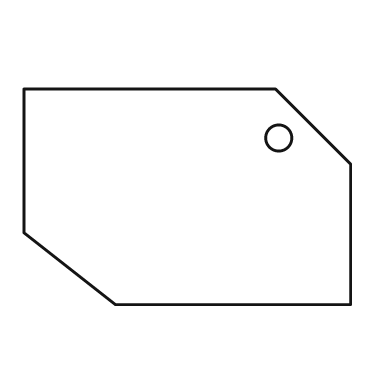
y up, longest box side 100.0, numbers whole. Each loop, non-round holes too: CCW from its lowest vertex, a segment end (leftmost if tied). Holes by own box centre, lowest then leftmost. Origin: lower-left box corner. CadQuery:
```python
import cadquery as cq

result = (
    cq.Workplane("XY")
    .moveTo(28.0, 0.0)
    .lineTo(100.0, 0.0)
    .lineTo(100.0, 43.0)
    .lineTo(77.0, 66.0)
    .lineTo(0.0, 66.0)
    .lineTo(0.0, 22.0)
    .close()
    .moveTo(78.0, 51.0)
    .circle(4.0)
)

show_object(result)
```